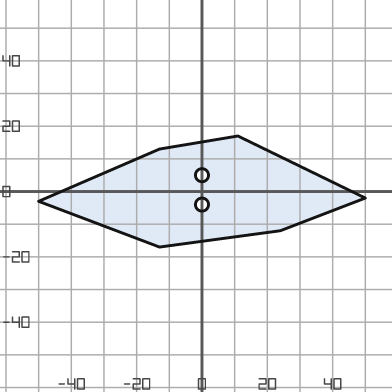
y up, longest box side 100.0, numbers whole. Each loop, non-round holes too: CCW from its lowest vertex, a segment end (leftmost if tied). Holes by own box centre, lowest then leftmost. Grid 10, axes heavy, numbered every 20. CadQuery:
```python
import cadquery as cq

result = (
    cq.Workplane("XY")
    .moveTo(-13.0, -17.0)
    .lineTo(24.0, -12.0)
    .lineTo(50.0, -2.0)
    .lineTo(11.0, 17.0)
    .lineTo(-13.0, 13.0)
    .lineTo(-50.0, -3.0)
    .close()
    .moveTo(0.0, -4.0)
    .circle(2.0)
    .moveTo(0.0, 5.0)
    .circle(2.0)
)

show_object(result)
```